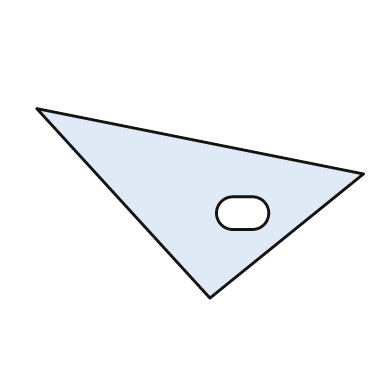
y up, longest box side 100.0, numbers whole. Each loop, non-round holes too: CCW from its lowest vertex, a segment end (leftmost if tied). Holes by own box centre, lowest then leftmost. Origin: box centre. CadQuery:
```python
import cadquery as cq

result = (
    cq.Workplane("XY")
    .moveTo(3.0, -29.0)
    .lineTo(50.0, 9.0)
    .lineTo(-50.0, 29.0)
    .close()
    .moveTo(10.0, -8.0)
    .lineTo(16.0, -8.0)
    .threePointArc((21.0, -3.0), (16.0, 2.0))
    .lineTo(10.0, 2.0)
    .threePointArc((5.0, -3.0), (10.0, -8.0))
    .close()
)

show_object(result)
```